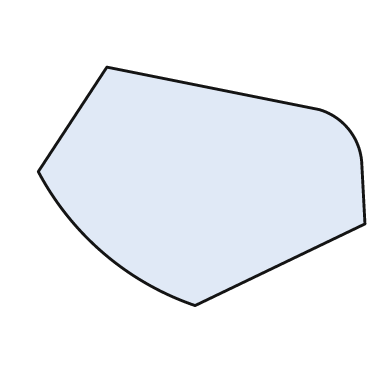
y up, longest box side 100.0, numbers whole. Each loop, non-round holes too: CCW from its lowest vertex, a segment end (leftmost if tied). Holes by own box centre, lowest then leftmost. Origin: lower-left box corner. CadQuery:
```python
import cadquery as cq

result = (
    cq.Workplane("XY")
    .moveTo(48.0, 0.0)
    .lineTo(100.0, 25.0)
    .lineTo(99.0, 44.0)
    .threePointArc((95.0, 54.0), (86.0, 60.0))
    .lineTo(21.0, 73.0)
    .lineTo(0.0, 41.0)
    .threePointArc((20.0, 16.0), (48.0, 0.0))
    .close()
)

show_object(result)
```